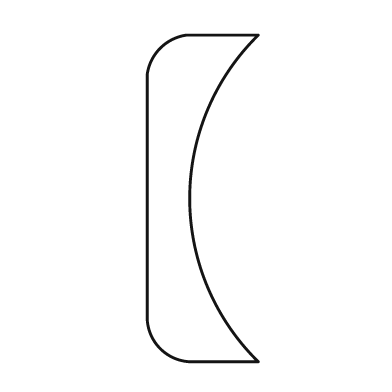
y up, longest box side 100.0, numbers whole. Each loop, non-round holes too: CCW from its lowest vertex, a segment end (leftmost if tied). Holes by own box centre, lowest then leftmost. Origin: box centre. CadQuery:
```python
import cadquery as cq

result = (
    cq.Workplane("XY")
    .moveTo(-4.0, -50.0)
    .lineTo(17.0, -50.0)
    .threePointArc((-4.0, 0.0), (17.0, 50.0))
    .lineTo(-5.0, 50.0)
    .threePointArc((-13.0, 46.0), (-17.0, 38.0))
    .lineTo(-17.0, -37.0)
    .threePointArc((-13.0, -46.0), (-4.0, -50.0))
    .close()
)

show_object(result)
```